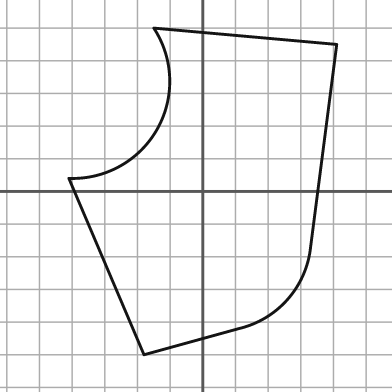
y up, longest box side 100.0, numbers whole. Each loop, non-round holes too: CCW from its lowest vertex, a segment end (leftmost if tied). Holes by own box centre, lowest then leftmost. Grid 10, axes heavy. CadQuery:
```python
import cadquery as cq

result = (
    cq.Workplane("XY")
    .moveTo(-18.0, -50.0)
    .lineTo(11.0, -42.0)
    .threePointArc((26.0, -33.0), (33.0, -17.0))
    .lineTo(41.0, 45.0)
    .lineTo(-15.0, 50.0)
    .threePointArc((-14.0, 19.0), (-41.0, 4.0))
    .close()
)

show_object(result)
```